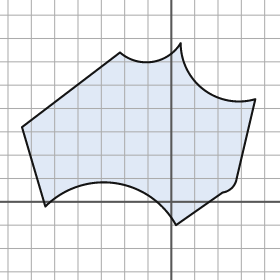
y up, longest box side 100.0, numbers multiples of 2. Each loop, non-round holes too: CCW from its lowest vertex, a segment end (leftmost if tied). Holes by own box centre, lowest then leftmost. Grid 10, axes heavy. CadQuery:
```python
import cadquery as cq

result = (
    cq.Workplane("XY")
    .moveTo(2.0, -10.0)
    .lineTo(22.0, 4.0)
    .threePointArc((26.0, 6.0), (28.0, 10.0))
    .lineTo(36.0, 44.0)
    .threePointArc((14.0, 48.0), (4.0, 68.0))
    .threePointArc((-8.0, 60.0), (-22.0, 64.0))
    .lineTo(-64.0, 32.0)
    .lineTo(-54.0, -2.0)
    .threePointArc((-24.0, 8.0), (2.0, -10.0))
    .close()
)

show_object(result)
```